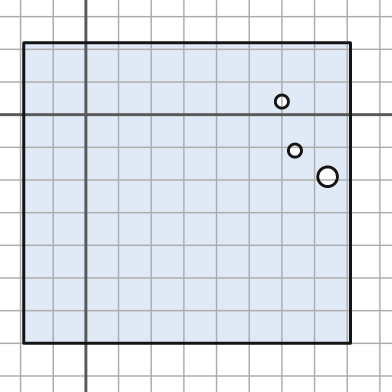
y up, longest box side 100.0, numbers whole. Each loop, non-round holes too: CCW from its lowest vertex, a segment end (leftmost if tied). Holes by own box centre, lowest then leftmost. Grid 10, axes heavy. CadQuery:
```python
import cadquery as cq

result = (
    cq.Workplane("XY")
    .moveTo(-19.0, -70.0)
    .lineTo(81.0, -70.0)
    .lineTo(81.0, 22.0)
    .lineTo(-19.0, 22.0)
    .close()
    .moveTo(74.0, -19.0)
    .circle(3.0)
    .moveTo(64.0, -11.0)
    .circle(2.0)
    .moveTo(60.0, 4.0)
    .circle(2.0)
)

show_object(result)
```